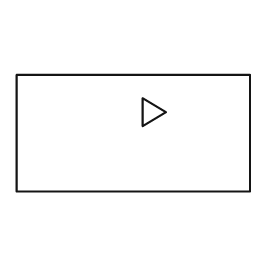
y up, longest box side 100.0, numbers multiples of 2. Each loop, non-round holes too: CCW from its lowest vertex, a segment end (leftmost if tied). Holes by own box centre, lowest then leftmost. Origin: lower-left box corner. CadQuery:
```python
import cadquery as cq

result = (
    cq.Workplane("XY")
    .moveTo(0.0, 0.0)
    .lineTo(100.0, 0.0)
    .lineTo(100.0, 50.0)
    .lineTo(0.0, 50.0)
    .close()
    .moveTo(54.0, 28.0)
    .lineTo(64.0, 34.0)
    .lineTo(54.0, 40.0)
    .close()
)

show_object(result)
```